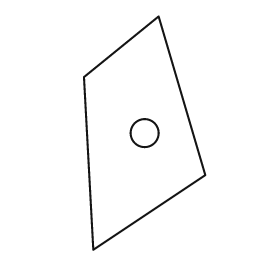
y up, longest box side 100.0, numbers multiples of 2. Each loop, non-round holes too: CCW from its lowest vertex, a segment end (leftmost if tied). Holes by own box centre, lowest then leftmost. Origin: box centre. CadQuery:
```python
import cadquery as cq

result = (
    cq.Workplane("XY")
    .moveTo(-22.0, -50.0)
    .lineTo(26.0, -18.0)
    .lineTo(6.0, 50.0)
    .lineTo(-26.0, 24.0)
    .close()
    .moveTo(0.0, 0.0)
    .circle(6.0)
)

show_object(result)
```